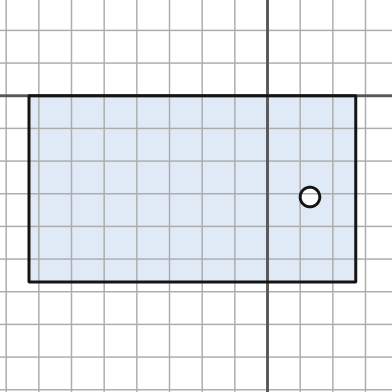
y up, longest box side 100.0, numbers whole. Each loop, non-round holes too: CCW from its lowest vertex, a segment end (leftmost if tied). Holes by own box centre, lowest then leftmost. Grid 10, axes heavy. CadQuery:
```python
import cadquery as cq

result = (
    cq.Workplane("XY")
    .moveTo(-73.0, -57.0)
    .lineTo(27.0, -57.0)
    .lineTo(27.0, 0.0)
    .lineTo(-73.0, 0.0)
    .close()
    .moveTo(13.0, -31.0)
    .circle(3.0)
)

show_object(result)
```